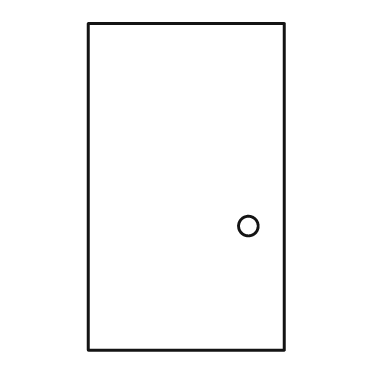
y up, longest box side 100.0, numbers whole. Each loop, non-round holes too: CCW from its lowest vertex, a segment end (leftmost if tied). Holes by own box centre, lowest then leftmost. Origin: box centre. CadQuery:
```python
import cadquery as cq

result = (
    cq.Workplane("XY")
    .moveTo(-30.0, -50.0)
    .lineTo(30.0, -50.0)
    .lineTo(30.0, 50.0)
    .lineTo(-30.0, 50.0)
    .close()
    .moveTo(19.0, -12.0)
    .circle(3.0)
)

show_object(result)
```